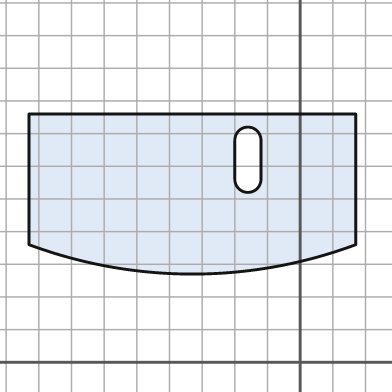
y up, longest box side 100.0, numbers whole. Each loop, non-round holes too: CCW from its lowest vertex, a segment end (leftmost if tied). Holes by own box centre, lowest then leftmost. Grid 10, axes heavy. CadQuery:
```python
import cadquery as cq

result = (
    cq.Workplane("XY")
    .moveTo(-83.0, 36.0)
    .threePointArc((-33.0, 27.0), (17.0, 36.0))
    .lineTo(17.0, 76.0)
    .lineTo(-83.0, 76.0)
    .close()
    .moveTo(-20.0, 56.0)
    .threePointArc((-16.0, 52.0), (-12.0, 56.0))
    .lineTo(-12.0, 68.0)
    .threePointArc((-16.0, 72.0), (-20.0, 68.0))
    .close()
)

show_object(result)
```